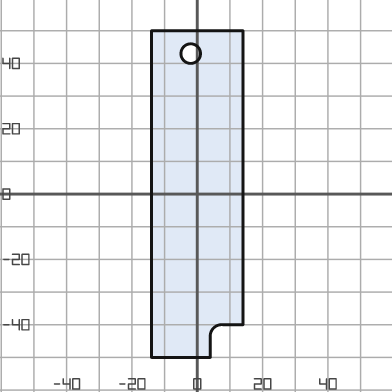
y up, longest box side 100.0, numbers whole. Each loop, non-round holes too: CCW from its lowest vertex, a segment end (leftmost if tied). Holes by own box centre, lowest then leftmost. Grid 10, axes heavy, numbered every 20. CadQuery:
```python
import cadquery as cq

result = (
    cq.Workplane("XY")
    .moveTo(-14.0, -50.0)
    .lineTo(4.0, -50.0)
    .lineTo(4.0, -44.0)
    .threePointArc((5.0, -41.0), (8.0, -40.0))
    .lineTo(14.0, -40.0)
    .lineTo(14.0, 50.0)
    .lineTo(-14.0, 50.0)
    .close()
    .moveTo(-2.0, 43.0)
    .circle(3.0)
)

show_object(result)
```